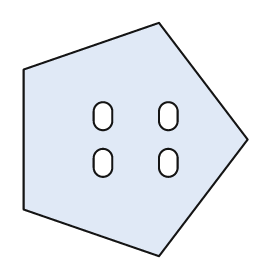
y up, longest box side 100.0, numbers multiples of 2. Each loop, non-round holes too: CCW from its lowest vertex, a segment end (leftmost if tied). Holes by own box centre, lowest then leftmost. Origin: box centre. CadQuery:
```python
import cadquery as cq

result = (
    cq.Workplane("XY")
    .moveTo(10.0, -50.0)
    .lineTo(48.0, 0.0)
    .lineTo(10.0, 50.0)
    .lineTo(-48.0, 30.0)
    .lineTo(-48.0, -30.0)
    .close()
    .moveTo(-18.0, -12.0)
    .threePointArc((-14.0, -16.0), (-10.0, -12.0))
    .lineTo(-10.0, -8.0)
    .threePointArc((-14.0, -4.0), (-18.0, -8.0))
    .close()
    .moveTo(10.0, -12.0)
    .threePointArc((14.0, -16.0), (18.0, -12.0))
    .lineTo(18.0, -8.0)
    .threePointArc((14.0, -4.0), (10.0, -8.0))
    .close()
    .moveTo(-18.0, 8.0)
    .threePointArc((-14.0, 4.0), (-10.0, 8.0))
    .lineTo(-10.0, 12.0)
    .threePointArc((-14.0, 16.0), (-18.0, 12.0))
    .close()
    .moveTo(10.0, 8.0)
    .threePointArc((14.0, 4.0), (18.0, 8.0))
    .lineTo(18.0, 12.0)
    .threePointArc((14.0, 16.0), (10.0, 12.0))
    .close()
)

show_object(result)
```